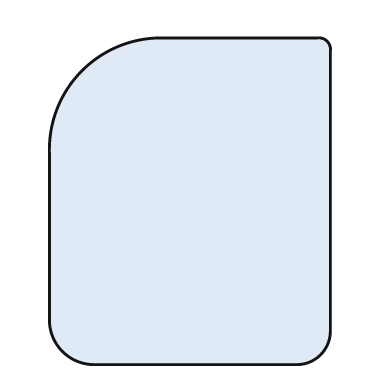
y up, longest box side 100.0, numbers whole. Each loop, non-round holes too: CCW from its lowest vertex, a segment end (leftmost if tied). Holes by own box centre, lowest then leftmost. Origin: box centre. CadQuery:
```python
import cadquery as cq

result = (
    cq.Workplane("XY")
    .moveTo(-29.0, -50.0)
    .lineTo(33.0, -50.0)
    .threePointArc((40.0, -47.0), (43.0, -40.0))
    .lineTo(43.0, 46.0)
    .threePointArc((42.0, 49.0), (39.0, 50.0))
    .lineTo(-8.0, 50.0)
    .threePointArc((-33.0, 40.0), (-43.0, 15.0))
    .lineTo(-43.0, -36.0)
    .threePointArc((-39.0, -46.0), (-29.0, -50.0))
    .close()
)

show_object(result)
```